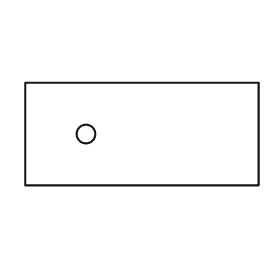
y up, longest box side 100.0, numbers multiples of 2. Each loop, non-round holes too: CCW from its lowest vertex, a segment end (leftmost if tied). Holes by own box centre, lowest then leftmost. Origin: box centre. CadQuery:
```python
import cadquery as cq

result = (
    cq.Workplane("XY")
    .moveTo(-50.0, -22.0)
    .lineTo(50.0, -22.0)
    .lineTo(50.0, 22.0)
    .lineTo(-50.0, 22.0)
    .close()
    .moveTo(-24.0, 0.0)
    .circle(4.0)
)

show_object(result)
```